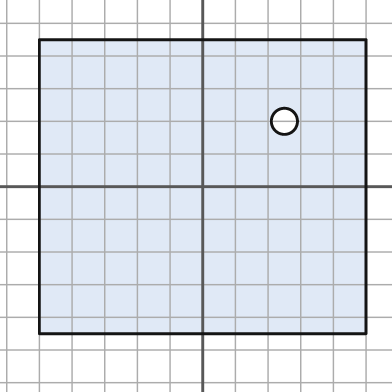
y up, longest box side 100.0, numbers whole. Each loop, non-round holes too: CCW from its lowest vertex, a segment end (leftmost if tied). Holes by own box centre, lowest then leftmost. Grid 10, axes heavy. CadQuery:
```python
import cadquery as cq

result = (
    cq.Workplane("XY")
    .moveTo(-50.0, -45.0)
    .lineTo(50.0, -45.0)
    .lineTo(50.0, 45.0)
    .lineTo(-50.0, 45.0)
    .close()
    .moveTo(25.0, 20.0)
    .circle(4.0)
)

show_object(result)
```